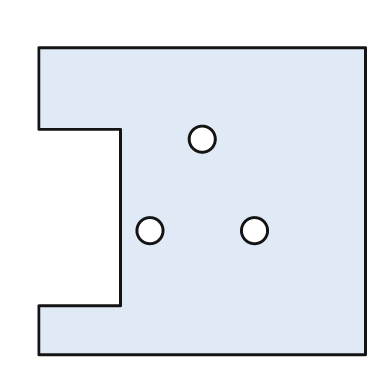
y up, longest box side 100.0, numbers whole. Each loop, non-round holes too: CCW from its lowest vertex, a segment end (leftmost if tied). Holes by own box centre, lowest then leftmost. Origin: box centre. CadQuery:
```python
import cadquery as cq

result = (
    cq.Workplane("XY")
    .moveTo(-50.0, -47.0)
    .lineTo(50.0, -47.0)
    .lineTo(50.0, 47.0)
    .lineTo(-50.0, 47.0)
    .lineTo(-50.0, 22.0)
    .lineTo(-25.0, 22.0)
    .lineTo(-25.0, -32.0)
    .lineTo(-50.0, -32.0)
    .close()
    .moveTo(-16.0, -9.0)
    .circle(4.0)
    .moveTo(16.0, -9.0)
    .circle(4.0)
    .moveTo(0.0, 19.0)
    .circle(4.0)
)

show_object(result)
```